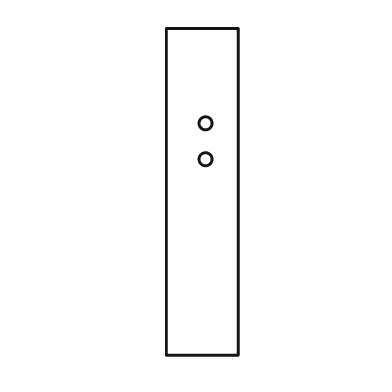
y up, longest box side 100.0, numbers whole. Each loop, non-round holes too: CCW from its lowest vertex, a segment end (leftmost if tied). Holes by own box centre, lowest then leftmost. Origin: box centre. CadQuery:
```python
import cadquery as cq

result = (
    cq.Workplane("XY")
    .moveTo(-11.0, -50.0)
    .lineTo(11.0, -50.0)
    .lineTo(11.0, 50.0)
    .lineTo(-11.0, 50.0)
    .close()
    .moveTo(1.0, 10.0)
    .circle(2.0)
    .moveTo(1.0, 21.0)
    .circle(2.0)
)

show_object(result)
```